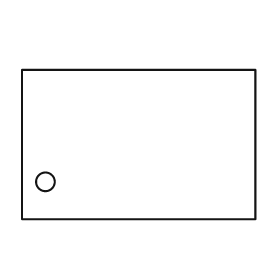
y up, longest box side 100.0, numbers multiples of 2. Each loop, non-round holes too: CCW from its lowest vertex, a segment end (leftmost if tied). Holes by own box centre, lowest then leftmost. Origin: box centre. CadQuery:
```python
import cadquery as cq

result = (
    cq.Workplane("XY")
    .moveTo(-50.0, -32.0)
    .lineTo(50.0, -32.0)
    .lineTo(50.0, 32.0)
    .lineTo(-50.0, 32.0)
    .close()
    .moveTo(-40.0, -16.0)
    .circle(4.0)
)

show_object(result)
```